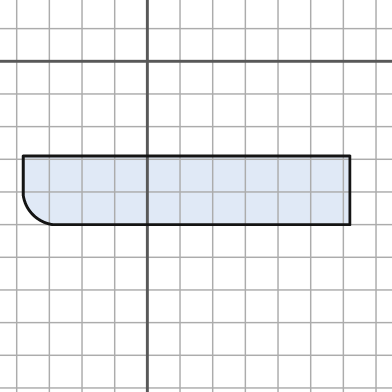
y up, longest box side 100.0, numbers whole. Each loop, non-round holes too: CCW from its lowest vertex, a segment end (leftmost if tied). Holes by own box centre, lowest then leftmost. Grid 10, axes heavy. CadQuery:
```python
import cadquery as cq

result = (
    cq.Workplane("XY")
    .moveTo(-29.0, -50.0)
    .lineTo(62.0, -50.0)
    .lineTo(62.0, -29.0)
    .lineTo(-38.0, -29.0)
    .lineTo(-38.0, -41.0)
    .threePointArc((-35.0, -47.0), (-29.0, -50.0))
    .close()
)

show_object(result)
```